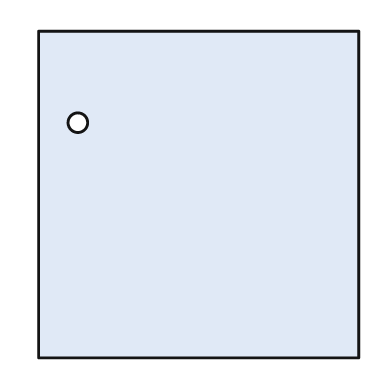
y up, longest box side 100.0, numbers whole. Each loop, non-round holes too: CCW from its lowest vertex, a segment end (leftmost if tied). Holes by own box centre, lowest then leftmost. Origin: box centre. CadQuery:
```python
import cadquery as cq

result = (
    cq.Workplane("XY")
    .moveTo(-49.0, -50.0)
    .lineTo(49.0, -50.0)
    .lineTo(49.0, 50.0)
    .lineTo(-49.0, 50.0)
    .close()
    .moveTo(-37.0, 22.0)
    .circle(3.0)
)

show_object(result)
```